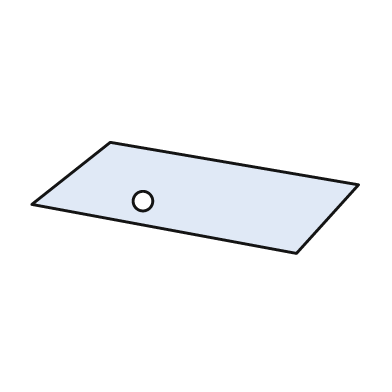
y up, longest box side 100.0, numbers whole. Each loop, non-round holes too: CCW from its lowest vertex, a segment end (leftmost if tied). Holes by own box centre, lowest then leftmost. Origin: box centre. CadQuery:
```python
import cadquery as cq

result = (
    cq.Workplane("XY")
    .moveTo(31.0, -17.0)
    .lineTo(50.0, 4.0)
    .lineTo(-26.0, 17.0)
    .lineTo(-50.0, -2.0)
    .close()
    .moveTo(-16.0, -1.0)
    .circle(3.0)
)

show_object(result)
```